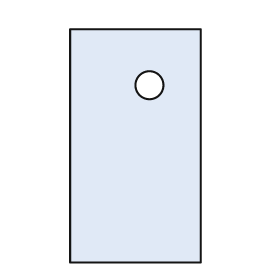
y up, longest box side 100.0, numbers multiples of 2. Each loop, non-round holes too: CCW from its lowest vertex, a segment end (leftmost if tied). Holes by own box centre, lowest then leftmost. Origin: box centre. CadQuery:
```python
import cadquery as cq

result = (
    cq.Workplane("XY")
    .moveTo(-28.0, -50.0)
    .lineTo(28.0, -50.0)
    .lineTo(28.0, 50.0)
    .lineTo(-28.0, 50.0)
    .close()
    .moveTo(6.0, 26.0)
    .circle(6.0)
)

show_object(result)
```